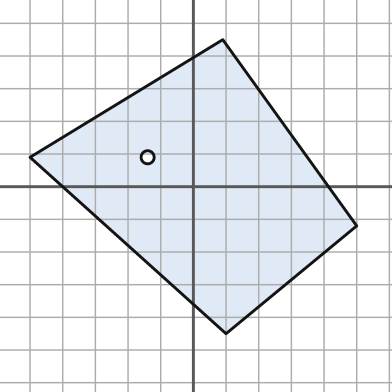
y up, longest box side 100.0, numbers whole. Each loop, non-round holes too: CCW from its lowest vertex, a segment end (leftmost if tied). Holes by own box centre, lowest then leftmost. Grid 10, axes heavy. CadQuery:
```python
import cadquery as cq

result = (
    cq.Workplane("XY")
    .moveTo(10.0, -45.0)
    .lineTo(50.0, -12.0)
    .lineTo(9.0, 45.0)
    .lineTo(-50.0, 9.0)
    .close()
    .moveTo(-14.0, 9.0)
    .circle(2.0)
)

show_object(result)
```